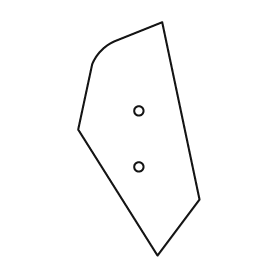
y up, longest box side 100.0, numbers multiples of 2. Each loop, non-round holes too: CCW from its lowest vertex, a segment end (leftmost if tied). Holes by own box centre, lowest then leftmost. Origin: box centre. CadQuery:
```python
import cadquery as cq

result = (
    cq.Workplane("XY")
    .moveTo(8.0, -50.0)
    .lineTo(26.0, -26.0)
    .lineTo(10.0, 50.0)
    .lineTo(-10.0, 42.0)
    .threePointArc((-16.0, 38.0), (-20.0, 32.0))
    .lineTo(-26.0, 4.0)
    .close()
    .moveTo(0.0, -12.0)
    .circle(2.0)
    .moveTo(0.0, 12.0)
    .circle(2.0)
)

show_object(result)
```